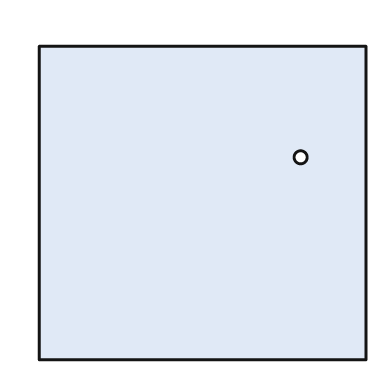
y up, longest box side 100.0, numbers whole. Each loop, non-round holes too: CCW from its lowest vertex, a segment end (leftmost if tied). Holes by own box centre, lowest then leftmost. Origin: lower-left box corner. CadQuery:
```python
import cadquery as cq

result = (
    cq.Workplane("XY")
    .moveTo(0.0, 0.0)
    .lineTo(100.0, 0.0)
    .lineTo(100.0, 96.0)
    .lineTo(0.0, 96.0)
    .close()
    .moveTo(80.0, 62.0)
    .circle(2.0)
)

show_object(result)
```